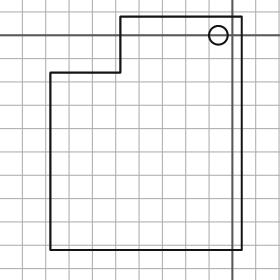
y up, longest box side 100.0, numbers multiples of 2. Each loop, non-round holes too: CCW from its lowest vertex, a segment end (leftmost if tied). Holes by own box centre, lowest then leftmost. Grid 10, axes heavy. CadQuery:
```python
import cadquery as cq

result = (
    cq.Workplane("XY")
    .moveTo(-78.0, -92.0)
    .lineTo(4.0, -92.0)
    .lineTo(4.0, 8.0)
    .lineTo(-48.0, 8.0)
    .lineTo(-48.0, -16.0)
    .lineTo(-78.0, -16.0)
    .close()
    .moveTo(-6.0, 0.0)
    .circle(4.0)
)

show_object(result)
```